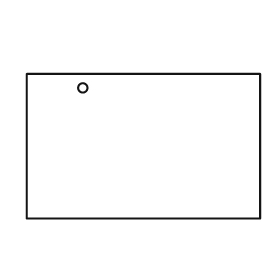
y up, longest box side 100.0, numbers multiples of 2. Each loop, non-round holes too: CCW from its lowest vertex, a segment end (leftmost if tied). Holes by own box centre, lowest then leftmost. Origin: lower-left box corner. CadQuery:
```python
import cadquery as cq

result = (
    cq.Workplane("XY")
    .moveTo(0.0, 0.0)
    .lineTo(100.0, 0.0)
    .lineTo(100.0, 62.0)
    .lineTo(0.0, 62.0)
    .close()
    .moveTo(24.0, 56.0)
    .circle(2.0)
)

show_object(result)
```